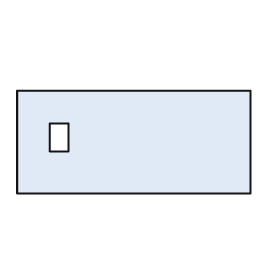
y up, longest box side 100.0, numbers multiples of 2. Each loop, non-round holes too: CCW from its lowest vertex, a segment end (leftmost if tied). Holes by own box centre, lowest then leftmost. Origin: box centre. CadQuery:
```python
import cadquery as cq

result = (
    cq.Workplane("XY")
    .moveTo(-50.0, -22.0)
    .lineTo(50.0, -22.0)
    .lineTo(50.0, 22.0)
    .lineTo(-50.0, 22.0)
    .close()
    .moveTo(-36.0, -4.0)
    .lineTo(-28.0, -4.0)
    .lineTo(-28.0, 8.0)
    .lineTo(-36.0, 8.0)
    .close()
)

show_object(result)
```